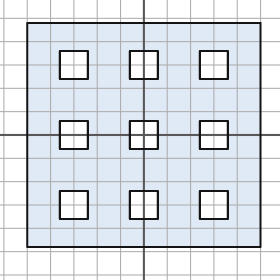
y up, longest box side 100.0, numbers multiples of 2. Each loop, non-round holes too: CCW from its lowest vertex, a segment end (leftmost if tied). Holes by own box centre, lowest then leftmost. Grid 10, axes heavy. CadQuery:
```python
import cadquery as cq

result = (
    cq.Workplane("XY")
    .moveTo(-50.0, -48.0)
    .lineTo(50.0, -48.0)
    .lineTo(50.0, 48.0)
    .lineTo(-50.0, 48.0)
    .close()
    .moveTo(-36.0, -36.0)
    .lineTo(-24.0, -36.0)
    .lineTo(-24.0, -24.0)
    .lineTo(-36.0, -24.0)
    .close()
    .moveTo(-6.0, -36.0)
    .lineTo(6.0, -36.0)
    .lineTo(6.0, -24.0)
    .lineTo(-6.0, -24.0)
    .close()
    .moveTo(24.0, -36.0)
    .lineTo(36.0, -36.0)
    .lineTo(36.0, -24.0)
    .lineTo(24.0, -24.0)
    .close()
    .moveTo(-36.0, -6.0)
    .lineTo(-24.0, -6.0)
    .lineTo(-24.0, 6.0)
    .lineTo(-36.0, 6.0)
    .close()
    .moveTo(-6.0, -6.0)
    .lineTo(6.0, -6.0)
    .lineTo(6.0, 6.0)
    .lineTo(-6.0, 6.0)
    .close()
    .moveTo(24.0, -6.0)
    .lineTo(36.0, -6.0)
    .lineTo(36.0, 6.0)
    .lineTo(24.0, 6.0)
    .close()
    .moveTo(-36.0, 24.0)
    .lineTo(-24.0, 24.0)
    .lineTo(-24.0, 36.0)
    .lineTo(-36.0, 36.0)
    .close()
    .moveTo(-6.0, 24.0)
    .lineTo(6.0, 24.0)
    .lineTo(6.0, 36.0)
    .lineTo(-6.0, 36.0)
    .close()
    .moveTo(24.0, 24.0)
    .lineTo(36.0, 24.0)
    .lineTo(36.0, 36.0)
    .lineTo(24.0, 36.0)
    .close()
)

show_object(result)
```